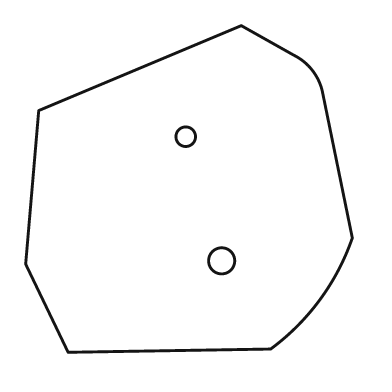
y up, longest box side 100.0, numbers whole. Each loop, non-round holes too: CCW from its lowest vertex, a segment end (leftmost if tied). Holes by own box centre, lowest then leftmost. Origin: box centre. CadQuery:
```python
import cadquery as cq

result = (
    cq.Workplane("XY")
    .moveTo(-37.0, -50.0)
    .lineTo(25.0, -49.0)
    .threePointArc((40.0, -34.0), (50.0, -15.0))
    .lineTo(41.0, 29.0)
    .threePointArc((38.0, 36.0), (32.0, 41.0))
    .lineTo(16.0, 50.0)
    .lineTo(-46.0, 24.0)
    .lineTo(-50.0, -23.0)
    .close()
    .moveTo(10.0, -22.0)
    .circle(4.0)
    .moveTo(-1.0, 16.0)
    .circle(3.0)
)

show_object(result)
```